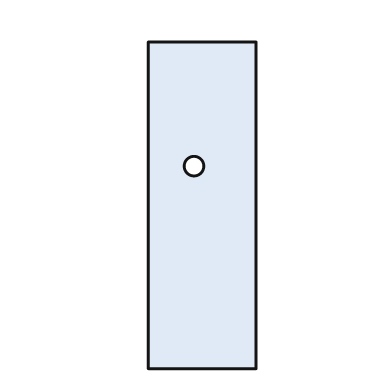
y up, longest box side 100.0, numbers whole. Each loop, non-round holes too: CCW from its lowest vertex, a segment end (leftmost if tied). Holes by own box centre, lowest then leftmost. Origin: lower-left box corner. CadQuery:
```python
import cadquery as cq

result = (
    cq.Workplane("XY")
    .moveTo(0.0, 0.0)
    .lineTo(33.0, 0.0)
    .lineTo(33.0, 100.0)
    .lineTo(0.0, 100.0)
    .close()
    .moveTo(14.0, 62.0)
    .circle(3.0)
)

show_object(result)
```